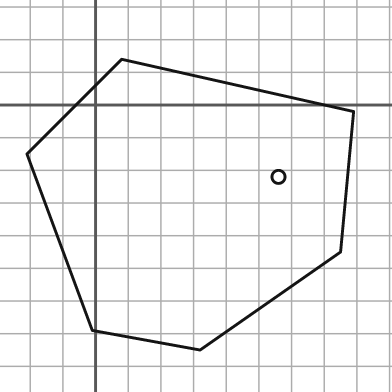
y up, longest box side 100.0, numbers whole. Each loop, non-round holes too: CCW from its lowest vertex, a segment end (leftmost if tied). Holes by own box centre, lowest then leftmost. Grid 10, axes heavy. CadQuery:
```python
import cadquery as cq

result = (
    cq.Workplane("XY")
    .moveTo(32.0, -75.0)
    .lineTo(75.0, -45.0)
    .lineTo(79.0, -2.0)
    .lineTo(8.0, 14.0)
    .lineTo(-21.0, -15.0)
    .lineTo(-1.0, -69.0)
    .close()
    .moveTo(56.0, -22.0)
    .circle(2.0)
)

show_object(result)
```